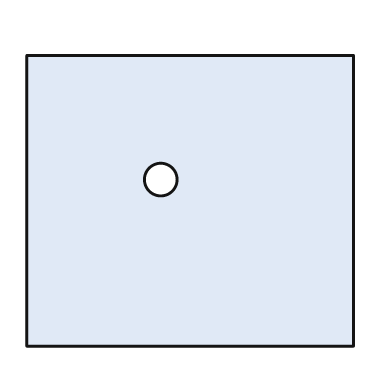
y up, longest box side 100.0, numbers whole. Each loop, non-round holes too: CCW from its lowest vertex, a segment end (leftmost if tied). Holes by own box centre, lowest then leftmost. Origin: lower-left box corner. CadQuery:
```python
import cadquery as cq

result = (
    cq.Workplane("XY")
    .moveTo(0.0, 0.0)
    .lineTo(100.0, 0.0)
    .lineTo(100.0, 89.0)
    .lineTo(0.0, 89.0)
    .close()
    .moveTo(41.0, 51.0)
    .circle(5.0)
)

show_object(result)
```